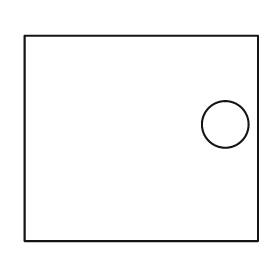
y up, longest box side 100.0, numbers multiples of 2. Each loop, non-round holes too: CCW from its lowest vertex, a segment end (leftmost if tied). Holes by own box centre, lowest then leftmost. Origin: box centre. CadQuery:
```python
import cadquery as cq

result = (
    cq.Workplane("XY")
    .moveTo(-50.0, -44.0)
    .lineTo(50.0, -44.0)
    .lineTo(50.0, 44.0)
    .lineTo(-50.0, 44.0)
    .close()
    .moveTo(36.0, 6.0)
    .circle(10.0)
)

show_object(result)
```